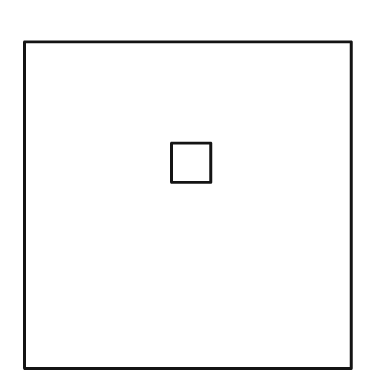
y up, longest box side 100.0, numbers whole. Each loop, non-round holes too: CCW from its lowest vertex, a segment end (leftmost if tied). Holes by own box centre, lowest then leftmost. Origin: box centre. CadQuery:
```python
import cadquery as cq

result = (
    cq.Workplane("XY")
    .moveTo(-50.0, -50.0)
    .lineTo(50.0, -50.0)
    .lineTo(50.0, 50.0)
    .lineTo(-50.0, 50.0)
    .close()
    .moveTo(-5.0, 7.0)
    .lineTo(7.0, 7.0)
    .lineTo(7.0, 19.0)
    .lineTo(-5.0, 19.0)
    .close()
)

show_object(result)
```